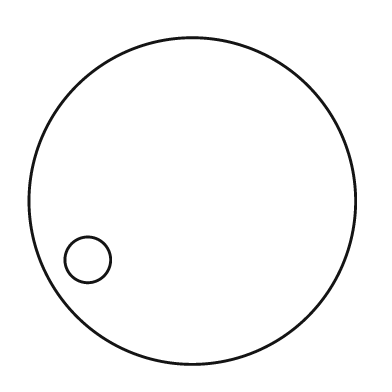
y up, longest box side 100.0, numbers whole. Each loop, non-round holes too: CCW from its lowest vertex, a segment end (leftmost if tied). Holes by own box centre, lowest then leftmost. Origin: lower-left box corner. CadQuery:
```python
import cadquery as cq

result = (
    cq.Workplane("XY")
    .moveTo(50.0, 50.0)
    .circle(50.0)
    .moveTo(18.0, 32.0)
    .circle(7.0)
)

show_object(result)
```